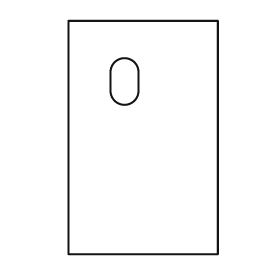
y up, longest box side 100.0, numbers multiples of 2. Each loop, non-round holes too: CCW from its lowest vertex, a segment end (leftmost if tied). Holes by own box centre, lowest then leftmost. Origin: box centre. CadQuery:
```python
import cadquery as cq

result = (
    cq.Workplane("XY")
    .moveTo(-32.0, -50.0)
    .lineTo(32.0, -50.0)
    .lineTo(32.0, 50.0)
    .lineTo(-32.0, 50.0)
    .close()
    .moveTo(-14.0, 20.0)
    .threePointArc((-8.0, 14.0), (-2.0, 20.0))
    .lineTo(-2.0, 28.0)
    .threePointArc((-8.0, 34.0), (-14.0, 28.0))
    .close()
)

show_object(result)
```